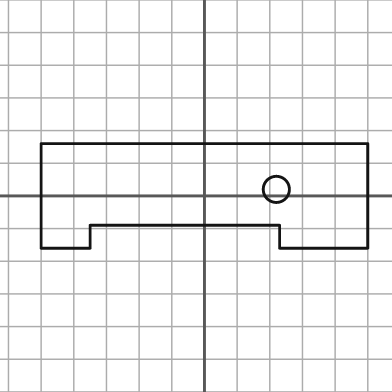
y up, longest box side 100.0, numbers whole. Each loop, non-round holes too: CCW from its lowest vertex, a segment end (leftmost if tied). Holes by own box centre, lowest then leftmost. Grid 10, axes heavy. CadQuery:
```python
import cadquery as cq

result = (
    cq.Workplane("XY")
    .moveTo(-50.0, -16.0)
    .lineTo(-35.0, -16.0)
    .lineTo(-35.0, -9.0)
    .lineTo(23.0, -9.0)
    .lineTo(23.0, -16.0)
    .lineTo(50.0, -16.0)
    .lineTo(50.0, 16.0)
    .lineTo(-50.0, 16.0)
    .close()
    .moveTo(22.0, 2.0)
    .circle(4.0)
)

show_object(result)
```